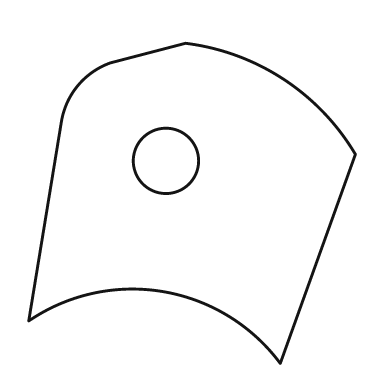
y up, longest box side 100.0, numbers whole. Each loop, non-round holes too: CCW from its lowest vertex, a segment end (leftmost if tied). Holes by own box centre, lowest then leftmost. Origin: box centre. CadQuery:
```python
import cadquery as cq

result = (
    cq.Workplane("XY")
    .moveTo(27.0, -49.0)
    .lineTo(50.0, 15.0)
    .threePointArc((28.0, 38.0), (-2.0, 49.0))
    .lineTo(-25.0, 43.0)
    .threePointArc((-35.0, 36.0), (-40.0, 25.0))
    .lineTo(-50.0, -36.0)
    .threePointArc((-9.0, -27.0), (27.0, -49.0))
    .close()
    .moveTo(-8.0, 13.0)
    .circle(10.0)
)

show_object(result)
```